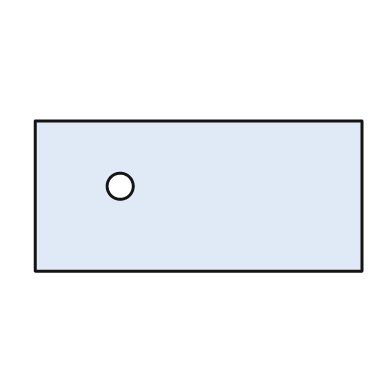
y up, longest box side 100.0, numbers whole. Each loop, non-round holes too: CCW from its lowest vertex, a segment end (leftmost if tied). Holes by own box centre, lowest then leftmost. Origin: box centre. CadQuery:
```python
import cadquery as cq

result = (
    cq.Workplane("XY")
    .moveTo(-50.0, -23.0)
    .lineTo(50.0, -23.0)
    .lineTo(50.0, 23.0)
    .lineTo(-50.0, 23.0)
    .close()
    .moveTo(-24.0, 3.0)
    .circle(4.0)
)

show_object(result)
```